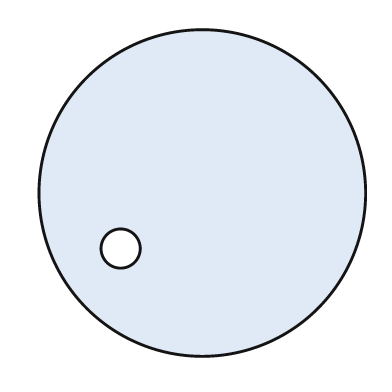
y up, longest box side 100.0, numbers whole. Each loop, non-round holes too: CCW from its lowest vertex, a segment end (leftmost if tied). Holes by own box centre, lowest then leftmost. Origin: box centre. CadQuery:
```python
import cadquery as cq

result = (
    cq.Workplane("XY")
    .moveTo(0.0, 0.0)
    .circle(50.0)
    .moveTo(-25.0, -17.0)
    .circle(6.0)
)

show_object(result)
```